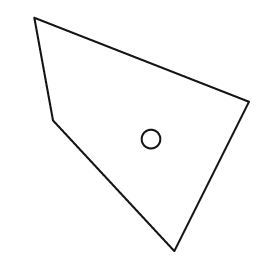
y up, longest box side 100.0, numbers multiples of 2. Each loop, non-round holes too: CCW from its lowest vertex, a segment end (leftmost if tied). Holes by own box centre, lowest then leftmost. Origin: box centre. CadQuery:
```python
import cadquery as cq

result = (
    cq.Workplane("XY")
    .moveTo(14.0, -50.0)
    .lineTo(46.0, 14.0)
    .lineTo(-46.0, 50.0)
    .lineTo(-38.0, 6.0)
    .close()
    .moveTo(4.0, -2.0)
    .circle(4.0)
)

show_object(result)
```